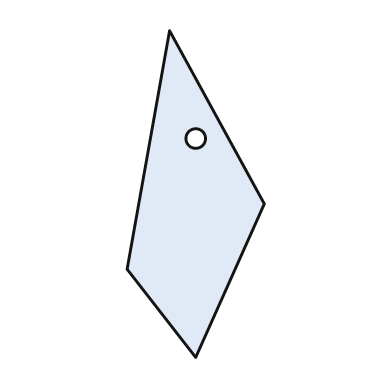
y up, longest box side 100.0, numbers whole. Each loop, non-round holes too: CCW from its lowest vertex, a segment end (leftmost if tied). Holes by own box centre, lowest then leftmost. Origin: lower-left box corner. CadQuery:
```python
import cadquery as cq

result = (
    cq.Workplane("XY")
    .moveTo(21.0, 0.0)
    .lineTo(42.0, 47.0)
    .lineTo(13.0, 100.0)
    .lineTo(0.0, 27.0)
    .close()
    .moveTo(21.0, 67.0)
    .circle(3.0)
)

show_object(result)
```